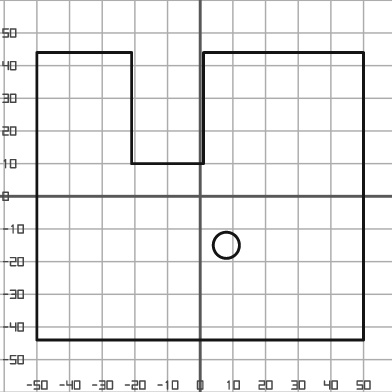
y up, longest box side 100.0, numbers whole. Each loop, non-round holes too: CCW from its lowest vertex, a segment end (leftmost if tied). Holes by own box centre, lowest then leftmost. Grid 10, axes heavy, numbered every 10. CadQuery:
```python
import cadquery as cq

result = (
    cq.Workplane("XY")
    .moveTo(-50.0, -44.0)
    .lineTo(50.0, -44.0)
    .lineTo(50.0, 44.0)
    .lineTo(1.0, 44.0)
    .lineTo(1.0, 10.0)
    .lineTo(-21.0, 10.0)
    .lineTo(-21.0, 44.0)
    .lineTo(-50.0, 44.0)
    .close()
    .moveTo(8.0, -15.0)
    .circle(4.0)
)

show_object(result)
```